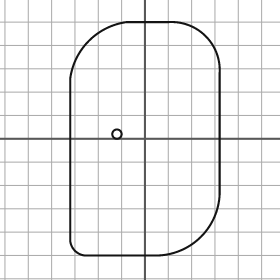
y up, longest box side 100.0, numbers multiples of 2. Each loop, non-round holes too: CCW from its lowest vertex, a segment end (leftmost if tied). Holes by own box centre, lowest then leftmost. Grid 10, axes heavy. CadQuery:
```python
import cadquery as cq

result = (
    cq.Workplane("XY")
    .moveTo(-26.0, -50.0)
    .lineTo(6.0, -50.0)
    .threePointArc((24.0, -42.0), (32.0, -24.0))
    .lineTo(32.0, 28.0)
    .threePointArc((26.0, 44.0), (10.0, 50.0))
    .lineTo(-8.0, 50.0)
    .threePointArc((-24.0, 42.0), (-32.0, 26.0))
    .lineTo(-32.0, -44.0)
    .threePointArc((-30.0, -48.0), (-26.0, -50.0))
    .close()
    .moveTo(-12.0, 2.0)
    .circle(2.0)
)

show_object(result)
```